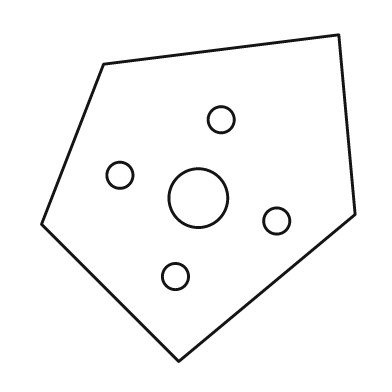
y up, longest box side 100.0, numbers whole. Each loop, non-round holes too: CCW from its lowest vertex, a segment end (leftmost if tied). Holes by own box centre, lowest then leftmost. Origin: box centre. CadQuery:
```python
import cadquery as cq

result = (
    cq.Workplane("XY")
    .moveTo(-6.0, -50.0)
    .lineTo(48.0, -5.0)
    .lineTo(43.0, 50.0)
    .lineTo(-29.0, 41.0)
    .lineTo(-48.0, -8.0)
    .close()
    .moveTo(-7.0, -24.0)
    .circle(4.0)
    .moveTo(24.0, -7.0)
    .circle(4.0)
    .moveTo(0.0, 0.0)
    .circle(9.0)
    .moveTo(-24.0, 7.0)
    .circle(4.0)
    .moveTo(7.0, 24.0)
    .circle(4.0)
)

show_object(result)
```